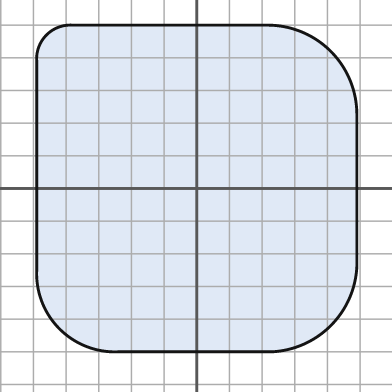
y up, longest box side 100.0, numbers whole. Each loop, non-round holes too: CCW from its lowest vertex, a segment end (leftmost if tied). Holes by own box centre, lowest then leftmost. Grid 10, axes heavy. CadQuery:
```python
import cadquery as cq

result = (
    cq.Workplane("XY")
    .moveTo(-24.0, -50.0)
    .lineTo(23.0, -50.0)
    .threePointArc((41.0, -42.0), (49.0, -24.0))
    .lineTo(49.0, 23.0)
    .threePointArc((41.0, 42.0), (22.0, 50.0))
    .lineTo(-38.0, 50.0)
    .threePointArc((-46.0, 47.0), (-49.0, 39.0))
    .lineTo(-49.0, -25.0)
    .threePointArc((-42.0, -43.0), (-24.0, -50.0))
    .close()
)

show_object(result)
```